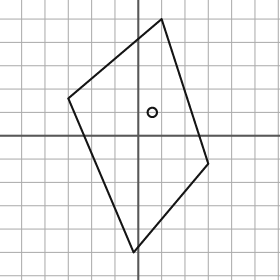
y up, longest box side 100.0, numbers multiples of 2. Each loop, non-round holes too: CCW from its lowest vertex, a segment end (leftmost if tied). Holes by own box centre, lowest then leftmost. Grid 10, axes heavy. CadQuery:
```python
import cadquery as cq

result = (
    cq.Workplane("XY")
    .moveTo(-2.0, -50.0)
    .lineTo(30.0, -12.0)
    .lineTo(10.0, 50.0)
    .lineTo(-30.0, 16.0)
    .close()
    .moveTo(6.0, 10.0)
    .circle(2.0)
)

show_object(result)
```